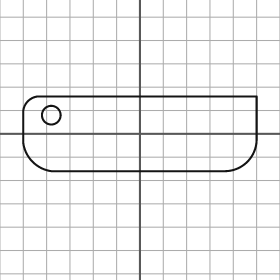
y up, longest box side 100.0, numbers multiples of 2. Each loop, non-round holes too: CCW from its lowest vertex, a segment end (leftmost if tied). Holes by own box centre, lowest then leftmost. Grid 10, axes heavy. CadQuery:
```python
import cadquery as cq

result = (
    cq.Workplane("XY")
    .moveTo(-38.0, -16.0)
    .lineTo(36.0, -16.0)
    .threePointArc((46.0, -12.0), (50.0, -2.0))
    .lineTo(50.0, 16.0)
    .lineTo(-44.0, 16.0)
    .threePointArc((-48.0, 14.0), (-50.0, 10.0))
    .lineTo(-50.0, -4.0)
    .threePointArc((-46.0, -12.0), (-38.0, -16.0))
    .close()
    .moveTo(-38.0, 8.0)
    .circle(4.0)
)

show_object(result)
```